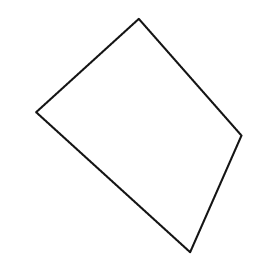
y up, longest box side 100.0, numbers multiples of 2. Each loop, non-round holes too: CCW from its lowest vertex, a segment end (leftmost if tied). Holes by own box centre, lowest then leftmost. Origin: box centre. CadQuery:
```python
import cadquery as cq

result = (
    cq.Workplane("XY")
    .moveTo(22.0, -50.0)
    .lineTo(44.0, 0.0)
    .lineTo(0.0, 50.0)
    .lineTo(-44.0, 10.0)
    .close()
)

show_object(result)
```